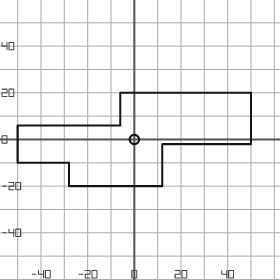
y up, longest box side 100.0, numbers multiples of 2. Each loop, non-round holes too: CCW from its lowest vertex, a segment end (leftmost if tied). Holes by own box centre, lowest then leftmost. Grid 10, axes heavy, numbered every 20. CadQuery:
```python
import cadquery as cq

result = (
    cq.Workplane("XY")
    .moveTo(-28.0, -20.0)
    .lineTo(12.0, -20.0)
    .lineTo(12.0, -2.0)
    .lineTo(50.0, -2.0)
    .lineTo(50.0, 20.0)
    .lineTo(-6.0, 20.0)
    .lineTo(-6.0, 6.0)
    .lineTo(-50.0, 6.0)
    .lineTo(-50.0, -10.0)
    .lineTo(-28.0, -10.0)
    .close()
    .moveTo(0.0, 0.0)
    .circle(2.0)
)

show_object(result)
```